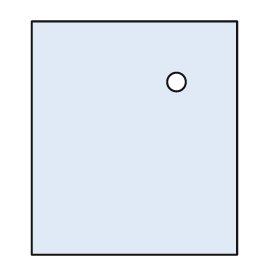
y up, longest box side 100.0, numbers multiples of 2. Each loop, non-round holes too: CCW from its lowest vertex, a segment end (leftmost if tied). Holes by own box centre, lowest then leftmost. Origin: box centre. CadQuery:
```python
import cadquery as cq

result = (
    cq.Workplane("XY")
    .moveTo(-44.0, -50.0)
    .lineTo(44.0, -50.0)
    .lineTo(44.0, 50.0)
    .lineTo(-44.0, 50.0)
    .close()
    .moveTo(18.0, 24.0)
    .circle(4.0)
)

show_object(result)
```